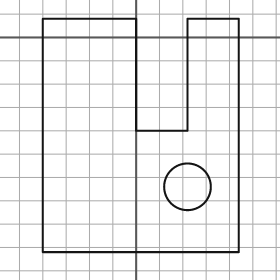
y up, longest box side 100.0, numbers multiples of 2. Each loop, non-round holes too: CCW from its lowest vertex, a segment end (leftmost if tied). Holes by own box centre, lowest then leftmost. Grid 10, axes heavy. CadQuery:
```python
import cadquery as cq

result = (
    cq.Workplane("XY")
    .moveTo(-40.0, -92.0)
    .lineTo(44.0, -92.0)
    .lineTo(44.0, 8.0)
    .lineTo(22.0, 8.0)
    .lineTo(22.0, -40.0)
    .lineTo(0.0, -40.0)
    .lineTo(0.0, 8.0)
    .lineTo(-40.0, 8.0)
    .close()
    .moveTo(22.0, -64.0)
    .circle(10.0)
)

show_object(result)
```